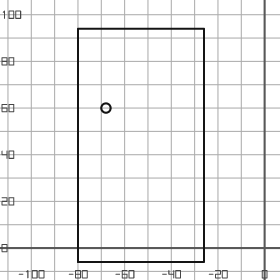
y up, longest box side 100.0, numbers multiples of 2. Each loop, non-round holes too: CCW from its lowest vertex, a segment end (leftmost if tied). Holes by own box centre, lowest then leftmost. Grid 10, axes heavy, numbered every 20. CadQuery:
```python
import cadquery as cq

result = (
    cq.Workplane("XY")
    .moveTo(-80.0, -6.0)
    .lineTo(-26.0, -6.0)
    .lineTo(-26.0, 94.0)
    .lineTo(-80.0, 94.0)
    .close()
    .moveTo(-68.0, 60.0)
    .circle(2.0)
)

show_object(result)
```